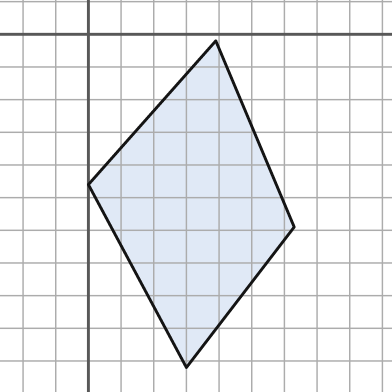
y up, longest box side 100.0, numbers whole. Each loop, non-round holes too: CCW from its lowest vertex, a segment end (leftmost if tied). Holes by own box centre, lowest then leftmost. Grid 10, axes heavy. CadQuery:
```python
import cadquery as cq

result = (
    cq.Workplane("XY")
    .moveTo(30.0, -102.0)
    .lineTo(63.0, -59.0)
    .lineTo(39.0, -2.0)
    .lineTo(0.0, -46.0)
    .close()
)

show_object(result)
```